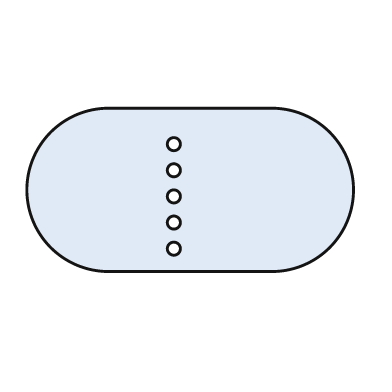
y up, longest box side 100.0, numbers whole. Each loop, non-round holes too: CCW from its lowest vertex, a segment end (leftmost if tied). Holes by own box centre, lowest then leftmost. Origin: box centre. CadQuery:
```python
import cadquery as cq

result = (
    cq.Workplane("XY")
    .moveTo(-25.0, -25.0)
    .lineTo(25.0, -25.0)
    .threePointArc((50.0, 0.0), (25.0, 25.0))
    .lineTo(-25.0, 25.0)
    .threePointArc((-50.0, 0.0), (-25.0, -25.0))
    .close()
    .moveTo(-5.0, -18.0)
    .circle(2.0)
    .moveTo(-5.0, -10.0)
    .circle(2.0)
    .moveTo(-5.0, -2.0)
    .circle(2.0)
    .moveTo(-5.0, 6.0)
    .circle(2.0)
    .moveTo(-5.0, 14.0)
    .circle(2.0)
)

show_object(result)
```